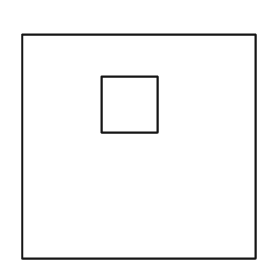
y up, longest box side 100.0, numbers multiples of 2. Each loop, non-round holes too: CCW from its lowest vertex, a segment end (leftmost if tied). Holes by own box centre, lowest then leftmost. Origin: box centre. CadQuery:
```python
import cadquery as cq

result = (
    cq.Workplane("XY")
    .moveTo(-50.0, -48.0)
    .lineTo(50.0, -48.0)
    .lineTo(50.0, 48.0)
    .lineTo(-50.0, 48.0)
    .close()
    .moveTo(-16.0, 6.0)
    .lineTo(8.0, 6.0)
    .lineTo(8.0, 30.0)
    .lineTo(-16.0, 30.0)
    .close()
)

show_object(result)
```